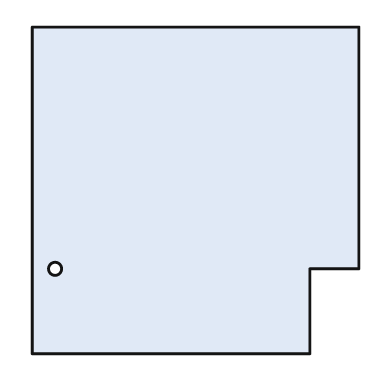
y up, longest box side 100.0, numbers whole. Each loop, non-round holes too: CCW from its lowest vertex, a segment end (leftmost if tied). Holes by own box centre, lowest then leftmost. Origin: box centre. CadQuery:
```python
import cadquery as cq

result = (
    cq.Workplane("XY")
    .moveTo(-50.0, -50.0)
    .lineTo(35.0, -50.0)
    .lineTo(35.0, -24.0)
    .lineTo(50.0, -24.0)
    .lineTo(50.0, 50.0)
    .lineTo(-50.0, 50.0)
    .close()
    .moveTo(-43.0, -24.0)
    .circle(2.0)
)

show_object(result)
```